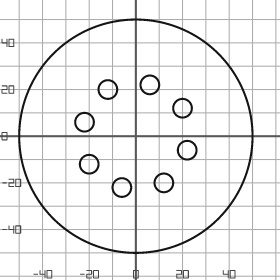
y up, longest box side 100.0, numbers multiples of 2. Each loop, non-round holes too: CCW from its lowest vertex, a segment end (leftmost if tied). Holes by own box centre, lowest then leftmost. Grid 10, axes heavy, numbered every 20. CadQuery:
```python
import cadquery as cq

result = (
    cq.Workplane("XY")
    .moveTo(0.0, 0.0)
    .circle(50.0)
    .moveTo(-6.0, -22.0)
    .circle(4.0)
    .moveTo(12.0, -20.0)
    .circle(4.0)
    .moveTo(-20.0, -12.0)
    .circle(4.0)
    .moveTo(22.0, -6.0)
    .circle(4.0)
    .moveTo(-22.0, 6.0)
    .circle(4.0)
    .moveTo(20.0, 12.0)
    .circle(4.0)
    .moveTo(-12.0, 20.0)
    .circle(4.0)
    .moveTo(6.0, 22.0)
    .circle(4.0)
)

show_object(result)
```